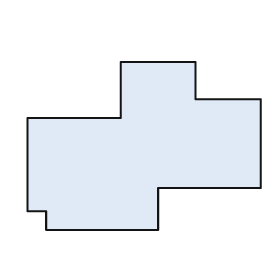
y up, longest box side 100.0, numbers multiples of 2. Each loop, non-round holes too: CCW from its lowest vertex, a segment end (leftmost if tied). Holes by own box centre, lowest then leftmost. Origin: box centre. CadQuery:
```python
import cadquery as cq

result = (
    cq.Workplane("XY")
    .moveTo(-42.0, -36.0)
    .lineTo(6.0, -36.0)
    .lineTo(6.0, -18.0)
    .lineTo(50.0, -18.0)
    .lineTo(50.0, 20.0)
    .lineTo(22.0, 20.0)
    .lineTo(22.0, 36.0)
    .lineTo(-10.0, 36.0)
    .lineTo(-10.0, 12.0)
    .lineTo(-50.0, 12.0)
    .lineTo(-50.0, -28.0)
    .lineTo(-42.0, -28.0)
    .close()
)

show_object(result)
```